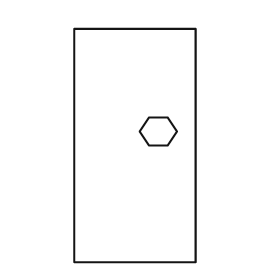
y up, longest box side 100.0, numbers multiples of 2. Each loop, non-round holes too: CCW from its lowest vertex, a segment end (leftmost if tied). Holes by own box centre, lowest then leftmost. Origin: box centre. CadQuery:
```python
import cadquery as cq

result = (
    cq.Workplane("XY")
    .moveTo(-26.0, -50.0)
    .lineTo(26.0, -50.0)
    .lineTo(26.0, 50.0)
    .lineTo(-26.0, 50.0)
    .close()
    .moveTo(6.0, 0.0)
    .lineTo(14.0, 0.0)
    .lineTo(18.0, 6.0)
    .lineTo(14.0, 12.0)
    .lineTo(6.0, 12.0)
    .lineTo(2.0, 6.0)
    .close()
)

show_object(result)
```